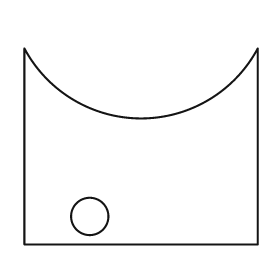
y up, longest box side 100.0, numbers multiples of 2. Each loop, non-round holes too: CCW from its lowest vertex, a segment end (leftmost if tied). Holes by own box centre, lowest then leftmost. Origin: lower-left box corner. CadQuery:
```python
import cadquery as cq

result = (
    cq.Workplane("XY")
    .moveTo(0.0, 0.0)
    .lineTo(100.0, 0.0)
    .lineTo(100.0, 84.0)
    .threePointArc((50.0, 54.0), (0.0, 84.0))
    .close()
    .moveTo(28.0, 12.0)
    .circle(8.0)
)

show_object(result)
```